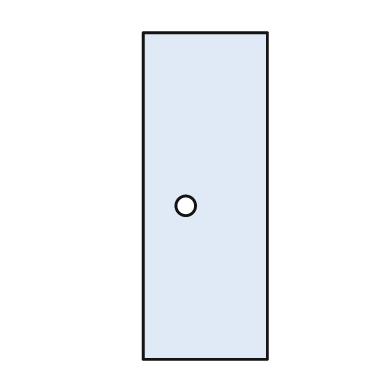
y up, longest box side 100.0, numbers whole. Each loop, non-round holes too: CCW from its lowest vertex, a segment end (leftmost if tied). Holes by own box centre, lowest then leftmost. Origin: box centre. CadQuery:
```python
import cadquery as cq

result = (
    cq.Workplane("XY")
    .moveTo(-19.0, -50.0)
    .lineTo(19.0, -50.0)
    .lineTo(19.0, 50.0)
    .lineTo(-19.0, 50.0)
    .close()
    .moveTo(-6.0, -3.0)
    .circle(3.0)
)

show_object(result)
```